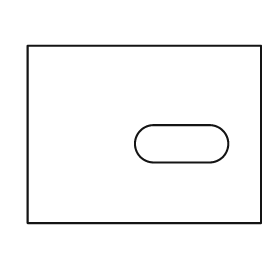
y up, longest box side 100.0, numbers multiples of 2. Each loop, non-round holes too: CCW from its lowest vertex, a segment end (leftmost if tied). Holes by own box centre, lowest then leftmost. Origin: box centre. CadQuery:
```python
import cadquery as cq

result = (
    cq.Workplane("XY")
    .moveTo(-50.0, -38.0)
    .lineTo(50.0, -38.0)
    .lineTo(50.0, 38.0)
    .lineTo(-50.0, 38.0)
    .close()
    .moveTo(4.0, -12.0)
    .lineTo(28.0, -12.0)
    .threePointArc((36.0, -4.0), (28.0, 4.0))
    .lineTo(4.0, 4.0)
    .threePointArc((-4.0, -4.0), (4.0, -12.0))
    .close()
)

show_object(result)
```